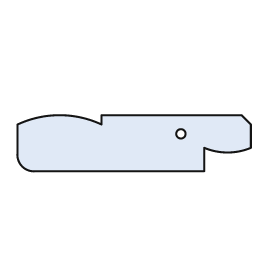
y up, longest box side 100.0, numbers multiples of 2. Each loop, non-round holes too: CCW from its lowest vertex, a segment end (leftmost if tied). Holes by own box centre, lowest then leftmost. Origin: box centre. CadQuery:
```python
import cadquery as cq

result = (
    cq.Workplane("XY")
    .moveTo(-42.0, -12.0)
    .lineTo(30.0, -12.0)
    .lineTo(30.0, -2.0)
    .threePointArc((40.0, -4.0), (50.0, -2.0))
    .lineTo(50.0, 8.0)
    .lineTo(46.0, 12.0)
    .lineTo(-14.0, 12.0)
    .lineTo(-14.0, 8.0)
    .threePointArc((-32.0, 12.0), (-50.0, 8.0))
    .lineTo(-50.0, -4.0)
    .threePointArc((-48.0, -10.0), (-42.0, -12.0))
    .close()
    .moveTo(20.0, 4.0)
    .circle(2.0)
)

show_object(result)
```